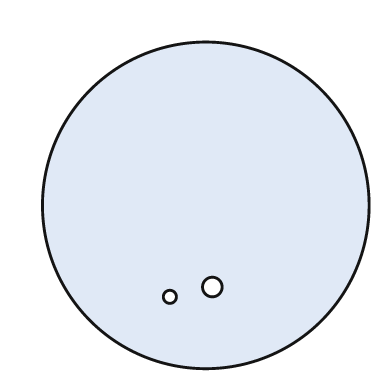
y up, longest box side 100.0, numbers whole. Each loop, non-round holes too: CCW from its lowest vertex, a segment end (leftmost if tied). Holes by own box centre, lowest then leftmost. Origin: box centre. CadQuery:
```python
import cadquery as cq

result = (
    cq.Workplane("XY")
    .moveTo(0.0, 0.0)
    .circle(50.0)
    .moveTo(-11.0, -28.0)
    .circle(2.0)
    .moveTo(2.0, -25.0)
    .circle(3.0)
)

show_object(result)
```